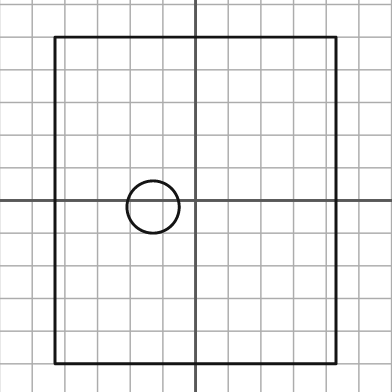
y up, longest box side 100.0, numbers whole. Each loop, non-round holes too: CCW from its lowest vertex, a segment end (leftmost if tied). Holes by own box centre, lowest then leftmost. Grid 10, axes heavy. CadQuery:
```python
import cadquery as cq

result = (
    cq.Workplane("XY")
    .moveTo(-43.0, -50.0)
    .lineTo(43.0, -50.0)
    .lineTo(43.0, 50.0)
    .lineTo(-43.0, 50.0)
    .close()
    .moveTo(-13.0, -2.0)
    .circle(8.0)
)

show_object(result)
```